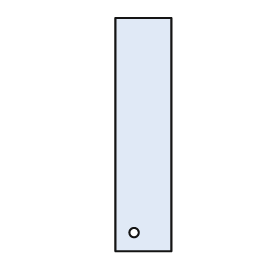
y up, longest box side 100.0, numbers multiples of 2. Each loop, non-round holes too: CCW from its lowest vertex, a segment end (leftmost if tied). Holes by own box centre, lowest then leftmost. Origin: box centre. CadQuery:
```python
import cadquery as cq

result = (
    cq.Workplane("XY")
    .moveTo(-12.0, -50.0)
    .lineTo(12.0, -50.0)
    .lineTo(12.0, 50.0)
    .lineTo(-12.0, 50.0)
    .close()
    .moveTo(-4.0, -42.0)
    .circle(2.0)
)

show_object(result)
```